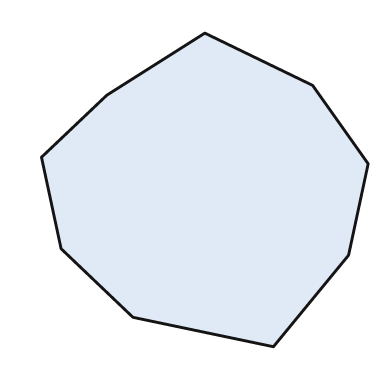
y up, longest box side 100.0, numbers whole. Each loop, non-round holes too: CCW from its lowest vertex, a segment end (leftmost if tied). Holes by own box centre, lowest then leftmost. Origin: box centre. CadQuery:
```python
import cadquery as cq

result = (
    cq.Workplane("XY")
    .moveTo(21.0, -48.0)
    .lineTo(44.0, -20.0)
    .lineTo(50.0, 8.0)
    .lineTo(33.0, 32.0)
    .lineTo(0.0, 48.0)
    .lineTo(-30.0, 29.0)
    .lineTo(-50.0, 10.0)
    .lineTo(-44.0, -18.0)
    .lineTo(-22.0, -39.0)
    .close()
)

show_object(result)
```